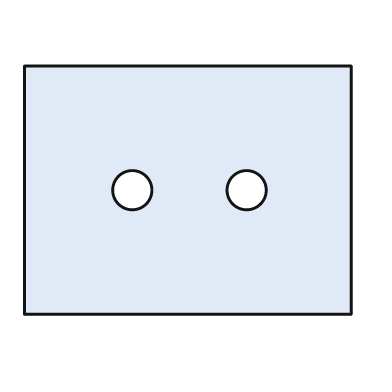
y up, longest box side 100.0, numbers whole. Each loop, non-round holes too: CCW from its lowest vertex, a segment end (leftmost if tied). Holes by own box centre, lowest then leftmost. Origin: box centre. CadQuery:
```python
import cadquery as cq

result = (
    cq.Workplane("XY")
    .moveTo(-50.0, -38.0)
    .lineTo(50.0, -38.0)
    .lineTo(50.0, 38.0)
    .lineTo(-50.0, 38.0)
    .close()
    .moveTo(-17.0, 0.0)
    .circle(6.0)
    .moveTo(18.0, 0.0)
    .circle(6.0)
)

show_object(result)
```